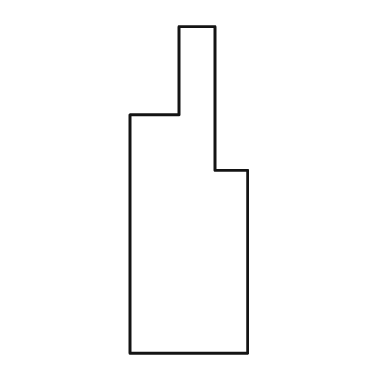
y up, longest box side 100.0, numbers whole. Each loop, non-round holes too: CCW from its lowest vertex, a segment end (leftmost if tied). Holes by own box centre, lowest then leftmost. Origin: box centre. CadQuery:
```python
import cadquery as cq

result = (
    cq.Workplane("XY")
    .moveTo(-18.0, -50.0)
    .lineTo(18.0, -50.0)
    .lineTo(18.0, 6.0)
    .lineTo(8.0, 6.0)
    .lineTo(8.0, 50.0)
    .lineTo(-3.0, 50.0)
    .lineTo(-3.0, 23.0)
    .lineTo(-18.0, 23.0)
    .close()
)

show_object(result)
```